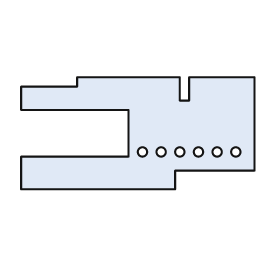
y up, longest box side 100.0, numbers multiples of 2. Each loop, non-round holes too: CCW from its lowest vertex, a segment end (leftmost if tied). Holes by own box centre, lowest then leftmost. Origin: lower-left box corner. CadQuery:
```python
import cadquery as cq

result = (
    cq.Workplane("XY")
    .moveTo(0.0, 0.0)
    .lineTo(66.0, 0.0)
    .lineTo(66.0, 8.0)
    .lineTo(100.0, 8.0)
    .lineTo(100.0, 48.0)
    .lineTo(72.0, 48.0)
    .lineTo(72.0, 38.0)
    .lineTo(68.0, 38.0)
    .lineTo(68.0, 48.0)
    .lineTo(24.0, 48.0)
    .lineTo(24.0, 44.0)
    .lineTo(0.0, 44.0)
    .lineTo(0.0, 34.0)
    .lineTo(46.0, 34.0)
    .lineTo(46.0, 14.0)
    .lineTo(0.0, 14.0)
    .close()
    .moveTo(52.0, 16.0)
    .circle(2.0)
    .moveTo(60.0, 16.0)
    .circle(2.0)
    .moveTo(68.0, 16.0)
    .circle(2.0)
    .moveTo(76.0, 16.0)
    .circle(2.0)
    .moveTo(84.0, 16.0)
    .circle(2.0)
    .moveTo(92.0, 16.0)
    .circle(2.0)
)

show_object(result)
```